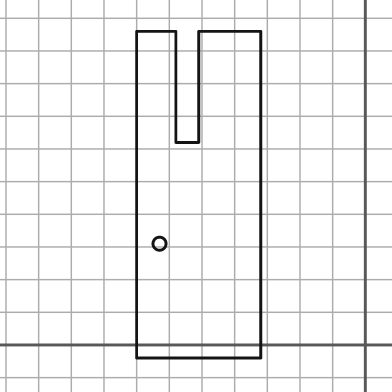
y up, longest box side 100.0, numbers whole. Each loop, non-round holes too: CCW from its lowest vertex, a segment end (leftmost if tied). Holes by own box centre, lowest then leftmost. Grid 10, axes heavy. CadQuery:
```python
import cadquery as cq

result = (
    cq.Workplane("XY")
    .moveTo(-70.0, -4.0)
    .lineTo(-32.0, -4.0)
    .lineTo(-32.0, 96.0)
    .lineTo(-51.0, 96.0)
    .lineTo(-51.0, 62.0)
    .lineTo(-58.0, 62.0)
    .lineTo(-58.0, 96.0)
    .lineTo(-70.0, 96.0)
    .close()
    .moveTo(-63.0, 31.0)
    .circle(2.0)
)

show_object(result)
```